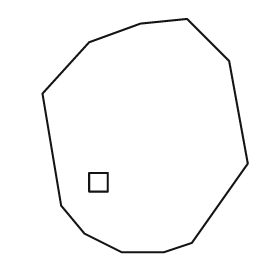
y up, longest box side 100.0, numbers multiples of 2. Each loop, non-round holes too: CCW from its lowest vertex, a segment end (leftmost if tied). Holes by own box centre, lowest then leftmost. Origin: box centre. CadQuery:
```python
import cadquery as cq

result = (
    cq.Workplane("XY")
    .moveTo(-10.0, -50.0)
    .lineTo(8.0, -50.0)
    .lineTo(20.0, -46.0)
    .lineTo(44.0, -12.0)
    .lineTo(36.0, 32.0)
    .lineTo(18.0, 50.0)
    .lineTo(-2.0, 48.0)
    .lineTo(-24.0, 40.0)
    .lineTo(-44.0, 18.0)
    .lineTo(-36.0, -30.0)
    .lineTo(-26.0, -42.0)
    .close()
    .moveTo(-24.0, -24.0)
    .lineTo(-16.0, -24.0)
    .lineTo(-16.0, -16.0)
    .lineTo(-24.0, -16.0)
    .close()
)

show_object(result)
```